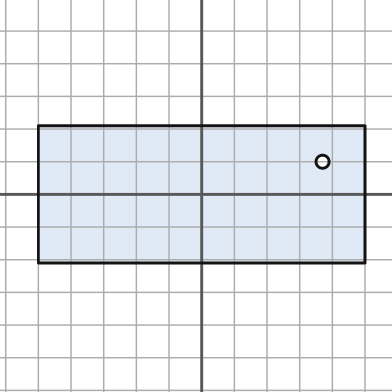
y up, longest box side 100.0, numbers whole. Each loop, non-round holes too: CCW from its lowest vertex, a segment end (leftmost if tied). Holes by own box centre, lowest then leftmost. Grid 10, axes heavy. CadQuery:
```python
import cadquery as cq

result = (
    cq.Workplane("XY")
    .moveTo(-50.0, -21.0)
    .lineTo(50.0, -21.0)
    .lineTo(50.0, 21.0)
    .lineTo(-50.0, 21.0)
    .close()
    .moveTo(37.0, 10.0)
    .circle(2.0)
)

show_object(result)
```